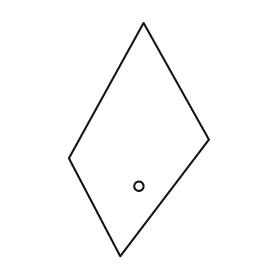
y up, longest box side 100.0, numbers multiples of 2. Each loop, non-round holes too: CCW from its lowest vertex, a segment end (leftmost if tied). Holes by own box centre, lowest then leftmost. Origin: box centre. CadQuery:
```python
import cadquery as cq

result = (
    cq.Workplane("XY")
    .moveTo(-8.0, -50.0)
    .lineTo(30.0, 0.0)
    .lineTo(2.0, 50.0)
    .lineTo(-30.0, -8.0)
    .close()
    .moveTo(0.0, -20.0)
    .circle(2.0)
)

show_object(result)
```